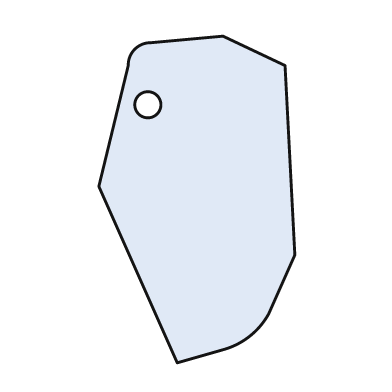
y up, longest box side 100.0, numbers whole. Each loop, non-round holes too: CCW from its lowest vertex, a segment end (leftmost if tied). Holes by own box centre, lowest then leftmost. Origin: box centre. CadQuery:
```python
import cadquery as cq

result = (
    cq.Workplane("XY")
    .moveTo(-6.0, -50.0)
    .lineTo(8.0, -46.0)
    .threePointArc((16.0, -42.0), (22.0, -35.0))
    .lineTo(30.0, -17.0)
    .lineTo(27.0, 41.0)
    .lineTo(8.0, 50.0)
    .lineTo(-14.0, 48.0)
    .threePointArc((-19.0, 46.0), (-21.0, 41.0))
    .lineTo(-30.0, 4.0)
    .close()
    .moveTo(-15.0, 29.0)
    .circle(4.0)
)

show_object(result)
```